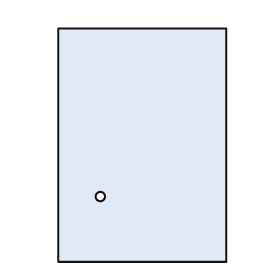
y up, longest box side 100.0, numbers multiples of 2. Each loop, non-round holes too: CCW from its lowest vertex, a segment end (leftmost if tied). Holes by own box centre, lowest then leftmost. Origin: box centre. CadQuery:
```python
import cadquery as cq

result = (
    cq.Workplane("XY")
    .moveTo(-36.0, -50.0)
    .lineTo(36.0, -50.0)
    .lineTo(36.0, 50.0)
    .lineTo(-36.0, 50.0)
    .close()
    .moveTo(-18.0, -22.0)
    .circle(2.0)
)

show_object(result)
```